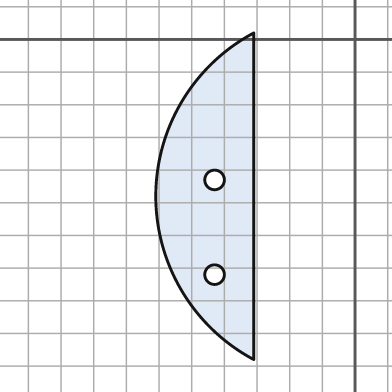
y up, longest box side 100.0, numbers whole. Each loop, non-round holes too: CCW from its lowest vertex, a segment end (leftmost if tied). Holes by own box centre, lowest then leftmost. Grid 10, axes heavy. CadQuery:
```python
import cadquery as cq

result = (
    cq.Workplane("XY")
    .moveTo(-31.0, -98.0)
    .lineTo(-31.0, 2.0)
    .threePointArc((-61.0, -48.0), (-31.0, -98.0))
    .close()
    .moveTo(-43.0, -72.0)
    .circle(3.0)
    .moveTo(-43.0, -43.0)
    .circle(3.0)
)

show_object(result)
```